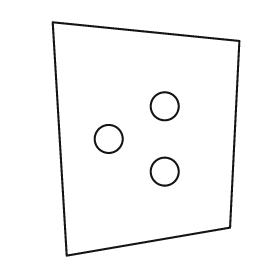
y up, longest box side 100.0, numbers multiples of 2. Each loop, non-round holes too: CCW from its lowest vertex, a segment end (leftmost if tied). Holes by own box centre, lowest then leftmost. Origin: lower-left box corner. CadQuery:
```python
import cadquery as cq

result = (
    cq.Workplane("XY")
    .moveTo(6.0, 0.0)
    .lineTo(76.0, 12.0)
    .lineTo(80.0, 92.0)
    .lineTo(0.0, 100.0)
    .close()
    .moveTo(48.0, 36.0)
    .circle(6.0)
    .moveTo(24.0, 50.0)
    .circle(6.0)
    .moveTo(48.0, 64.0)
    .circle(6.0)
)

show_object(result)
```